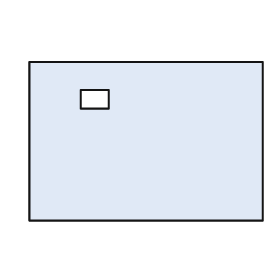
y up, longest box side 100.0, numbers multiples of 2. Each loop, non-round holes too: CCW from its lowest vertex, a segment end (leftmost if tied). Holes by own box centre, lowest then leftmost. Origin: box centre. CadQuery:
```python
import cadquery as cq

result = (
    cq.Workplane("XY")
    .moveTo(-50.0, -34.0)
    .lineTo(50.0, -34.0)
    .lineTo(50.0, 34.0)
    .lineTo(-50.0, 34.0)
    .close()
    .moveTo(-28.0, 14.0)
    .lineTo(-16.0, 14.0)
    .lineTo(-16.0, 22.0)
    .lineTo(-28.0, 22.0)
    .close()
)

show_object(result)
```